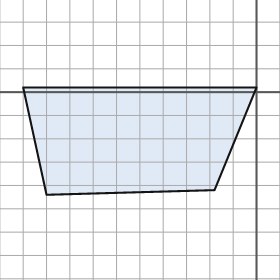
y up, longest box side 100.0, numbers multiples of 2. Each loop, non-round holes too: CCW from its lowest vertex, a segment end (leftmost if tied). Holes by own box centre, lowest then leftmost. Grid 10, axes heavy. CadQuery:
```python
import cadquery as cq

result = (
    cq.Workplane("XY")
    .moveTo(-90.0, -44.0)
    .lineTo(-18.0, -42.0)
    .lineTo(0.0, 2.0)
    .lineTo(-100.0, 2.0)
    .close()
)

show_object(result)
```